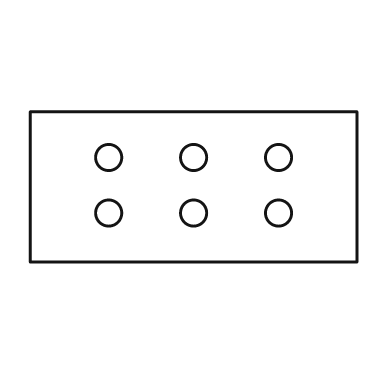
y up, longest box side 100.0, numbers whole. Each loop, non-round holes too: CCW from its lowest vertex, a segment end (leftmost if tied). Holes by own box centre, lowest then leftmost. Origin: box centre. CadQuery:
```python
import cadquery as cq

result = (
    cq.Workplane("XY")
    .moveTo(-50.0, -23.0)
    .lineTo(50.0, -23.0)
    .lineTo(50.0, 23.0)
    .lineTo(-50.0, 23.0)
    .close()
    .moveTo(-26.0, -8.0)
    .circle(4.0)
    .moveTo(0.0, -8.0)
    .circle(4.0)
    .moveTo(26.0, -8.0)
    .circle(4.0)
    .moveTo(-26.0, 9.0)
    .circle(4.0)
    .moveTo(0.0, 9.0)
    .circle(4.0)
    .moveTo(26.0, 9.0)
    .circle(4.0)
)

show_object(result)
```